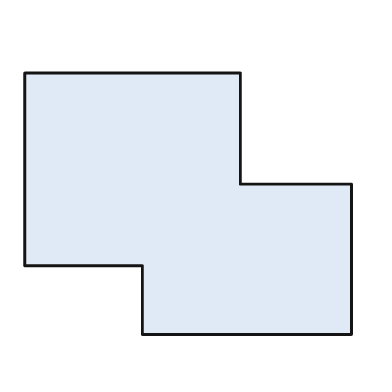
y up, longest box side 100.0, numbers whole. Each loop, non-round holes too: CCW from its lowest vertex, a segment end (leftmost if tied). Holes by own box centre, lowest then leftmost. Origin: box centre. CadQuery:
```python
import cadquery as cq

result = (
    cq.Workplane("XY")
    .moveTo(-14.0, -40.0)
    .lineTo(50.0, -40.0)
    .lineTo(50.0, 6.0)
    .lineTo(16.0, 6.0)
    .lineTo(16.0, 40.0)
    .lineTo(-50.0, 40.0)
    .lineTo(-50.0, -19.0)
    .lineTo(-14.0, -19.0)
    .close()
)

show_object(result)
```